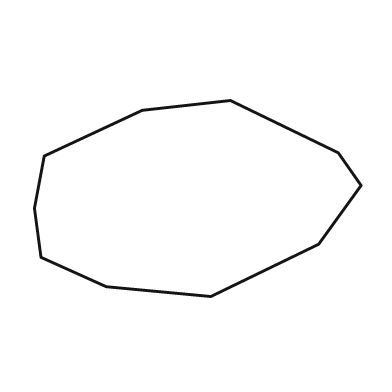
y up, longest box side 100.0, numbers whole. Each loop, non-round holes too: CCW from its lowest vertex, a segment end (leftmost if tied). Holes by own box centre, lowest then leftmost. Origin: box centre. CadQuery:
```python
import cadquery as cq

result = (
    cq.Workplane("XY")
    .moveTo(4.0, -30.0)
    .lineTo(37.0, -14.0)
    .lineTo(50.0, 4.0)
    .lineTo(43.0, 14.0)
    .lineTo(10.0, 30.0)
    .lineTo(-17.0, 27.0)
    .lineTo(-47.0, 13.0)
    .lineTo(-50.0, -3.0)
    .lineTo(-48.0, -18.0)
    .lineTo(-28.0, -27.0)
    .close()
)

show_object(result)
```